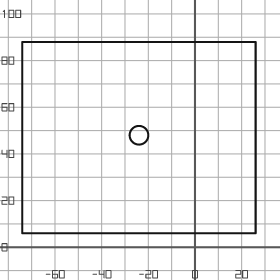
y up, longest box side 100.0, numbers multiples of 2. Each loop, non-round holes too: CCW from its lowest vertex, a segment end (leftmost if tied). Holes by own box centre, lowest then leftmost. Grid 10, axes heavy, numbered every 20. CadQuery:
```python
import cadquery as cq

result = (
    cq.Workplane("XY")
    .moveTo(-74.0, 6.0)
    .lineTo(26.0, 6.0)
    .lineTo(26.0, 88.0)
    .lineTo(-74.0, 88.0)
    .close()
    .moveTo(-24.0, 48.0)
    .circle(4.0)
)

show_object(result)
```